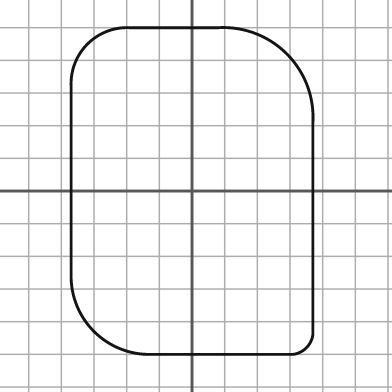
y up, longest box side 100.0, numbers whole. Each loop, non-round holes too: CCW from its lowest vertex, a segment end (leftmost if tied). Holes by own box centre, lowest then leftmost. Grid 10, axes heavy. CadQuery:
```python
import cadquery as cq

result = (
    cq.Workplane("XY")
    .moveTo(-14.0, -50.0)
    .lineTo(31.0, -50.0)
    .threePointArc((35.0, -48.0), (37.0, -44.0))
    .lineTo(37.0, 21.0)
    .threePointArc((29.0, 42.0), (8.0, 50.0))
    .lineTo(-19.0, 50.0)
    .threePointArc((-32.0, 45.0), (-37.0, 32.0))
    .lineTo(-37.0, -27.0)
    .threePointArc((-30.0, -43.0), (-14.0, -50.0))
    .close()
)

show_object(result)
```